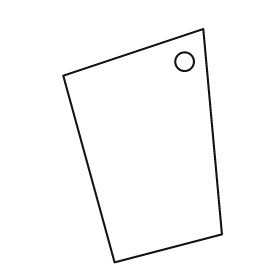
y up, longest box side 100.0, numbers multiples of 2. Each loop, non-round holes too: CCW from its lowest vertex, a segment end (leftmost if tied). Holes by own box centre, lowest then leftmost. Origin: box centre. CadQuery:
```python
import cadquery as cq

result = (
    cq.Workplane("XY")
    .moveTo(-12.0, -50.0)
    .lineTo(34.0, -38.0)
    .lineTo(26.0, 50.0)
    .lineTo(-34.0, 30.0)
    .close()
    .moveTo(18.0, 36.0)
    .circle(4.0)
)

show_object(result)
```